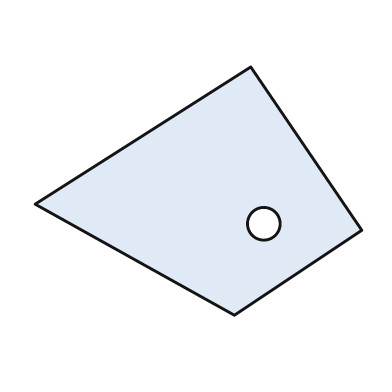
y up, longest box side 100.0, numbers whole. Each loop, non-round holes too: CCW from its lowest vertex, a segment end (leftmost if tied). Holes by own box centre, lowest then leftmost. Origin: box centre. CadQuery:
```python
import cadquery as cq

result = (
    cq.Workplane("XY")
    .moveTo(11.0, -38.0)
    .lineTo(50.0, -12.0)
    .lineTo(16.0, 38.0)
    .lineTo(-50.0, -4.0)
    .close()
    .moveTo(20.0, -10.0)
    .circle(5.0)
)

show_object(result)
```